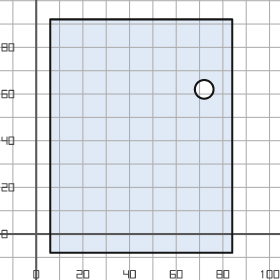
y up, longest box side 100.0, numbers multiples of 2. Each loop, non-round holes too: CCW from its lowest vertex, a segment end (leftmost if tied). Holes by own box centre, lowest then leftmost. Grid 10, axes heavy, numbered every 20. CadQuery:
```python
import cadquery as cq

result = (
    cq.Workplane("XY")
    .moveTo(6.0, -8.0)
    .lineTo(84.0, -8.0)
    .lineTo(84.0, 92.0)
    .lineTo(6.0, 92.0)
    .close()
    .moveTo(72.0, 62.0)
    .circle(4.0)
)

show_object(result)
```